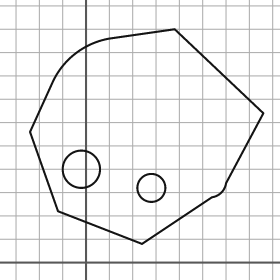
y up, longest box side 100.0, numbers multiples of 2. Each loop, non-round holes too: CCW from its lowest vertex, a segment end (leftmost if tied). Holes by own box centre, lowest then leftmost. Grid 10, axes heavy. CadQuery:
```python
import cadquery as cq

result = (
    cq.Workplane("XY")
    .moveTo(24.0, 8.0)
    .lineTo(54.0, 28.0)
    .threePointArc((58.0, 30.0), (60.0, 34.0))
    .lineTo(76.0, 64.0)
    .lineTo(38.0, 100.0)
    .lineTo(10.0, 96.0)
    .threePointArc((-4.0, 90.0), (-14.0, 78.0))
    .lineTo(-24.0, 56.0)
    .lineTo(-12.0, 22.0)
    .close()
    .moveTo(28.0, 32.0)
    .circle(6.0)
    .moveTo(-2.0, 40.0)
    .circle(8.0)
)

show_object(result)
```